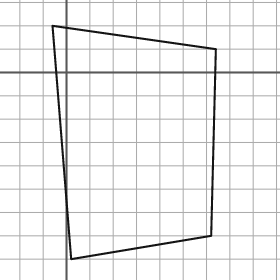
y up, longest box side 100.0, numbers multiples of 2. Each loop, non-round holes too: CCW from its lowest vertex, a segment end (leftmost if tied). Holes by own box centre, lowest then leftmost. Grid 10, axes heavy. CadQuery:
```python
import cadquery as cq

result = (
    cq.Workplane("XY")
    .moveTo(2.0, -80.0)
    .lineTo(62.0, -70.0)
    .lineTo(64.0, 10.0)
    .lineTo(-6.0, 20.0)
    .close()
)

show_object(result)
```